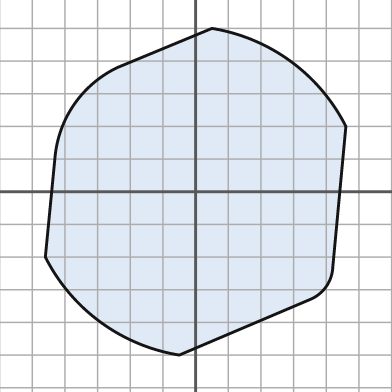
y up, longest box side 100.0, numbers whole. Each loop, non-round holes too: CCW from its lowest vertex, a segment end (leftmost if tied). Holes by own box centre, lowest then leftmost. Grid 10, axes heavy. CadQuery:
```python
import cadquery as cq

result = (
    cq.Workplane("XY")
    .moveTo(-5.0, -50.0)
    .lineTo(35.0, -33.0)
    .threePointArc((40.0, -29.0), (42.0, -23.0))
    .lineTo(46.0, 20.0)
    .threePointArc((29.0, 40.0), (5.0, 50.0))
    .lineTo(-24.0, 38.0)
    .threePointArc((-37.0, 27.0), (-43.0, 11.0))
    .lineTo(-46.0, -20.0)
    .threePointArc((-29.0, -40.0), (-5.0, -50.0))
    .close()
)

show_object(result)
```